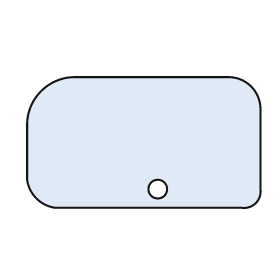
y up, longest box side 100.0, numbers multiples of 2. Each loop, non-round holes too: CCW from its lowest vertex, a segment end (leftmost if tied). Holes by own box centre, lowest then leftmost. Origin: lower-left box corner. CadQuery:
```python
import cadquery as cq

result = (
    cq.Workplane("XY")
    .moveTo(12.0, 0.0)
    .lineTo(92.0, 0.0)
    .threePointArc((98.0, 2.0), (100.0, 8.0))
    .lineTo(100.0, 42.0)
    .threePointArc((96.0, 52.0), (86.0, 56.0))
    .lineTo(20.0, 56.0)
    .threePointArc((6.0, 50.0), (0.0, 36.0))
    .lineTo(0.0, 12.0)
    .threePointArc((4.0, 4.0), (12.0, 0.0))
    .close()
    .moveTo(56.0, 8.0)
    .circle(4.0)
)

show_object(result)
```